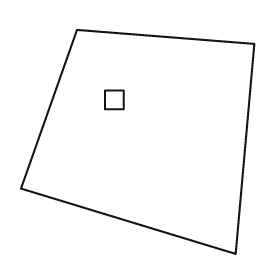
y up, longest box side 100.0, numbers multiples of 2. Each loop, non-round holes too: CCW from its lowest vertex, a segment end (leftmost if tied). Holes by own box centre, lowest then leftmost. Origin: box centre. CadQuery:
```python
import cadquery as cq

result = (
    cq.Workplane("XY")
    .moveTo(42.0, -48.0)
    .lineTo(50.0, 42.0)
    .lineTo(-26.0, 48.0)
    .lineTo(-50.0, -20.0)
    .close()
    .moveTo(-14.0, 14.0)
    .lineTo(-6.0, 14.0)
    .lineTo(-6.0, 22.0)
    .lineTo(-14.0, 22.0)
    .close()
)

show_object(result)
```